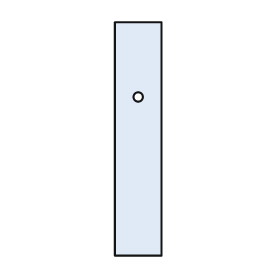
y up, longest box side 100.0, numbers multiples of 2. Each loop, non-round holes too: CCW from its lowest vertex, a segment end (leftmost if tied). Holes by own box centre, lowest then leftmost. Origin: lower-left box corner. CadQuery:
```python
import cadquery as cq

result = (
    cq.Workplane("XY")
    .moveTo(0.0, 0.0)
    .lineTo(20.0, 0.0)
    .lineTo(20.0, 100.0)
    .lineTo(0.0, 100.0)
    .close()
    .moveTo(10.0, 68.0)
    .circle(2.0)
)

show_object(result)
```